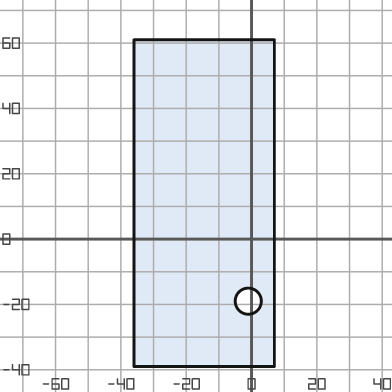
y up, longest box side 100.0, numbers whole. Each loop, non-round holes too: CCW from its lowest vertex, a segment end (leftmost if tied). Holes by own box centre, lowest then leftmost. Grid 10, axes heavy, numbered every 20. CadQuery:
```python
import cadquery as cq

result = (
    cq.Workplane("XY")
    .moveTo(-36.0, -39.0)
    .lineTo(7.0, -39.0)
    .lineTo(7.0, 61.0)
    .lineTo(-36.0, 61.0)
    .close()
    .moveTo(-1.0, -19.0)
    .circle(4.0)
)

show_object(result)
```